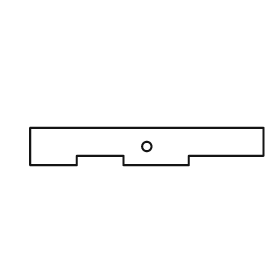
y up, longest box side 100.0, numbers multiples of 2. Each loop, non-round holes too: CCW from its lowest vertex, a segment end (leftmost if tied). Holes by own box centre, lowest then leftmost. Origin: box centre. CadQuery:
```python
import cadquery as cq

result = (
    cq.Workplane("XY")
    .moveTo(-50.0, -8.0)
    .lineTo(-30.0, -8.0)
    .lineTo(-30.0, -4.0)
    .lineTo(-10.0, -4.0)
    .lineTo(-10.0, -8.0)
    .lineTo(18.0, -8.0)
    .lineTo(18.0, -4.0)
    .lineTo(50.0, -4.0)
    .lineTo(50.0, 8.0)
    .lineTo(-50.0, 8.0)
    .close()
    .moveTo(0.0, 0.0)
    .circle(2.0)
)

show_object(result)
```